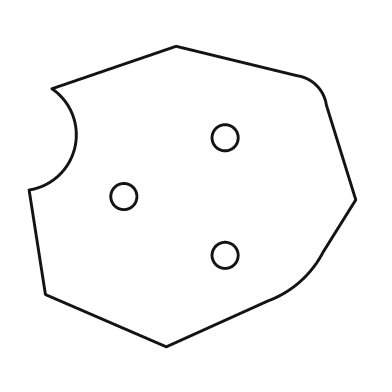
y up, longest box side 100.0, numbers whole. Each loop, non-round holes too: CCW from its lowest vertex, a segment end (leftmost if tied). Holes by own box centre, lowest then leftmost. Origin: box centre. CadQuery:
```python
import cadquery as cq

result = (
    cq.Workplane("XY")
    .moveTo(-8.0, -46.0)
    .lineTo(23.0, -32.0)
    .threePointArc((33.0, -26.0), (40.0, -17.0))
    .lineTo(50.0, -1.0)
    .lineTo(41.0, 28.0)
    .threePointArc((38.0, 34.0), (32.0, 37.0))
    .lineTo(-5.0, 46.0)
    .lineTo(-43.0, 33.0)
    .threePointArc((-36.0, 15.0), (-50.0, 2.0))
    .lineTo(-45.0, -30.0)
    .close()
    .moveTo(10.0, -18.0)
    .circle(4.0)
    .moveTo(-21.0, 0.0)
    .circle(4.0)
    .moveTo(10.0, 18.0)
    .circle(4.0)
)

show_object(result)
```